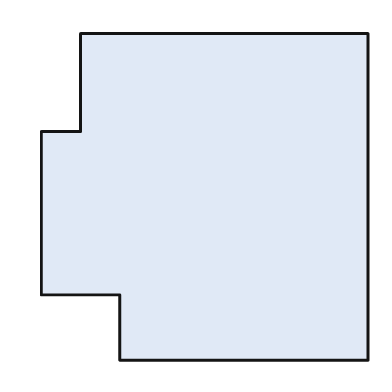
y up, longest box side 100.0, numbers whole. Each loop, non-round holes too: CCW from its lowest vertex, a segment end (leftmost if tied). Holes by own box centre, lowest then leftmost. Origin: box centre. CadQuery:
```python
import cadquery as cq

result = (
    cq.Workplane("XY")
    .moveTo(-26.0, -50.0)
    .lineTo(50.0, -50.0)
    .lineTo(50.0, 50.0)
    .lineTo(-38.0, 50.0)
    .lineTo(-38.0, 20.0)
    .lineTo(-50.0, 20.0)
    .lineTo(-50.0, -30.0)
    .lineTo(-26.0, -30.0)
    .close()
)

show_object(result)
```